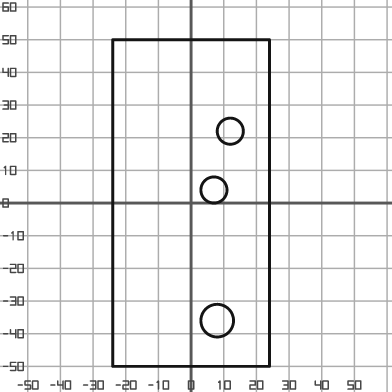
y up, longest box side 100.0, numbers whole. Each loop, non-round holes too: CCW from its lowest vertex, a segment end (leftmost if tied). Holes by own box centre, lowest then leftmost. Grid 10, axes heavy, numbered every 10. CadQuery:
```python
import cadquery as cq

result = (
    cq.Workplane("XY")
    .moveTo(-24.0, -50.0)
    .lineTo(24.0, -50.0)
    .lineTo(24.0, 50.0)
    .lineTo(-24.0, 50.0)
    .close()
    .moveTo(8.0, -36.0)
    .circle(5.0)
    .moveTo(7.0, 4.0)
    .circle(4.0)
    .moveTo(12.0, 22.0)
    .circle(4.0)
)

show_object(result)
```